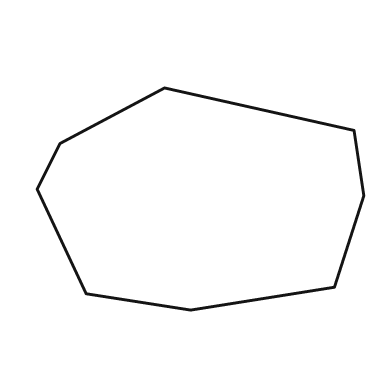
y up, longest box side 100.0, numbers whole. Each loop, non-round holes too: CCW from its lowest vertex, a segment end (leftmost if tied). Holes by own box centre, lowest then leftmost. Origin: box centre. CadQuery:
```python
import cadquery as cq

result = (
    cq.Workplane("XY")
    .moveTo(-3.0, -34.0)
    .lineTo(41.0, -27.0)
    .lineTo(50.0, 1.0)
    .lineTo(47.0, 21.0)
    .lineTo(-11.0, 34.0)
    .lineTo(-43.0, 17.0)
    .lineTo(-50.0, 3.0)
    .lineTo(-35.0, -29.0)
    .close()
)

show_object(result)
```